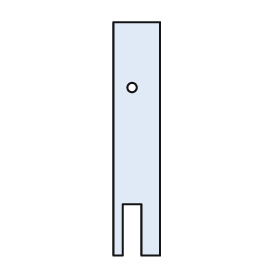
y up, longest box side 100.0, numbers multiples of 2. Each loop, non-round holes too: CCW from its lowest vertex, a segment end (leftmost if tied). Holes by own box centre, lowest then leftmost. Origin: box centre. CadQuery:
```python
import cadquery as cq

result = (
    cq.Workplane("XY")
    .moveTo(-10.0, -50.0)
    .lineTo(-6.0, -50.0)
    .lineTo(-6.0, -28.0)
    .lineTo(2.0, -28.0)
    .lineTo(2.0, -50.0)
    .lineTo(10.0, -50.0)
    .lineTo(10.0, 50.0)
    .lineTo(-10.0, 50.0)
    .close()
    .moveTo(-2.0, 22.0)
    .circle(2.0)
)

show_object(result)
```